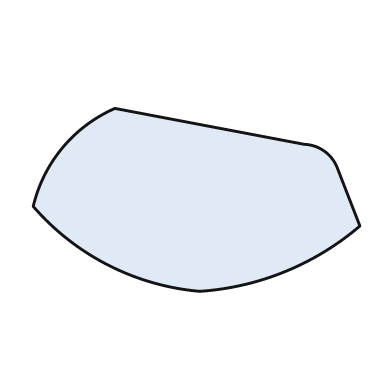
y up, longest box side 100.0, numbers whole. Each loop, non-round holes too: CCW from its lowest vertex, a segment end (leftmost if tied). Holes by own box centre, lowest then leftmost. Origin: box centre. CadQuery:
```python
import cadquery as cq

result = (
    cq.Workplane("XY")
    .moveTo(1.0, -28.0)
    .threePointArc((27.0, -22.0), (50.0, -8.0))
    .lineTo(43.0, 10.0)
    .threePointArc((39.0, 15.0), (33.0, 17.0))
    .lineTo(-25.0, 28.0)
    .threePointArc((-41.0, 16.0), (-50.0, -2.0))
    .threePointArc((-27.0, -20.0), (1.0, -28.0))
    .close()
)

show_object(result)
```